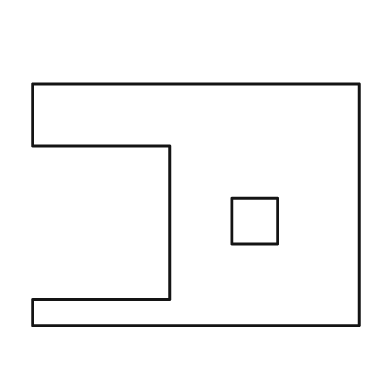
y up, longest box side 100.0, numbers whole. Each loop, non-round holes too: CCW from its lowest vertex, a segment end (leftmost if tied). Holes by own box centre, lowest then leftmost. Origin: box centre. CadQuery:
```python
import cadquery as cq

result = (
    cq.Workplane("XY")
    .moveTo(-50.0, -37.0)
    .lineTo(50.0, -37.0)
    .lineTo(50.0, 37.0)
    .lineTo(-50.0, 37.0)
    .lineTo(-50.0, 18.0)
    .lineTo(-8.0, 18.0)
    .lineTo(-8.0, -29.0)
    .lineTo(-50.0, -29.0)
    .close()
    .moveTo(11.0, -12.0)
    .lineTo(25.0, -12.0)
    .lineTo(25.0, 2.0)
    .lineTo(11.0, 2.0)
    .close()
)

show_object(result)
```